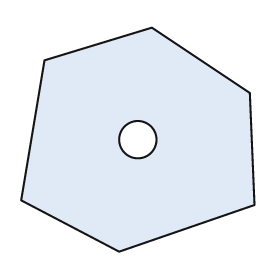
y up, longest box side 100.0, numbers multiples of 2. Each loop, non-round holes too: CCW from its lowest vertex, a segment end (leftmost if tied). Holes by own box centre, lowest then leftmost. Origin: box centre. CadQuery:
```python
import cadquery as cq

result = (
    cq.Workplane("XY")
    .moveTo(-8.0, -48.0)
    .lineTo(50.0, -28.0)
    .lineTo(48.0, 20.0)
    .lineTo(6.0, 48.0)
    .lineTo(-40.0, 34.0)
    .lineTo(-50.0, -26.0)
    .close()
    .moveTo(0.0, 0.0)
    .circle(8.0)
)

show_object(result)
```